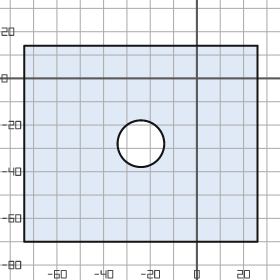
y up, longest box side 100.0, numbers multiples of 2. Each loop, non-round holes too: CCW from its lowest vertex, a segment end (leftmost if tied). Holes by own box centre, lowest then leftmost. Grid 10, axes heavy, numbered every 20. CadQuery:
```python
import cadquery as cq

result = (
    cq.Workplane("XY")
    .moveTo(-74.0, -70.0)
    .lineTo(26.0, -70.0)
    .lineTo(26.0, 14.0)
    .lineTo(-74.0, 14.0)
    .close()
    .moveTo(-24.0, -28.0)
    .circle(10.0)
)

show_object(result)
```